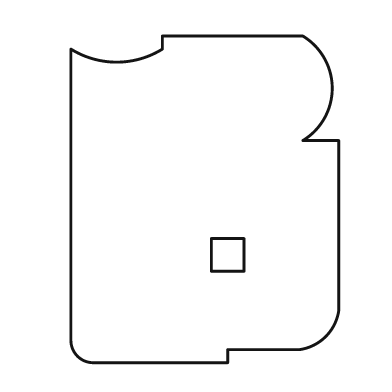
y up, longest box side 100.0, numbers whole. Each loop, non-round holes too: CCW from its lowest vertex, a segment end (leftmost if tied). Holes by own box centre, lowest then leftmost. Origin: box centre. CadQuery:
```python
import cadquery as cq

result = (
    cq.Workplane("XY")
    .moveTo(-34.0, -50.0)
    .lineTo(7.0, -50.0)
    .lineTo(7.0, -46.0)
    .lineTo(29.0, -46.0)
    .threePointArc((37.0, -42.0), (41.0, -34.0))
    .lineTo(41.0, 18.0)
    .lineTo(30.0, 18.0)
    .threePointArc((39.0, 34.0), (30.0, 50.0))
    .lineTo(-13.0, 50.0)
    .lineTo(-13.0, 46.0)
    .threePointArc((-27.0, 42.0), (-41.0, 46.0))
    .lineTo(-41.0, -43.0)
    .threePointArc((-39.0, -48.0), (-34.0, -50.0))
    .close()
    .moveTo(2.0, -22.0)
    .lineTo(12.0, -22.0)
    .lineTo(12.0, -12.0)
    .lineTo(2.0, -12.0)
    .close()
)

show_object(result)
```